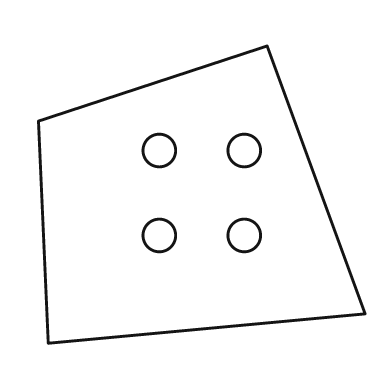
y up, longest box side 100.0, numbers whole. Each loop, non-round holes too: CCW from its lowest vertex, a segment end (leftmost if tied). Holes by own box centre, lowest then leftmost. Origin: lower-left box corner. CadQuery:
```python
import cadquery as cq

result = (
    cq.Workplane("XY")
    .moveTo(3.0, 0.0)
    .lineTo(100.0, 9.0)
    .lineTo(70.0, 91.0)
    .lineTo(0.0, 68.0)
    .close()
    .moveTo(37.0, 33.0)
    .circle(5.0)
    .moveTo(63.0, 33.0)
    .circle(5.0)
    .moveTo(37.0, 59.0)
    .circle(5.0)
    .moveTo(63.0, 59.0)
    .circle(5.0)
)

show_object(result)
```